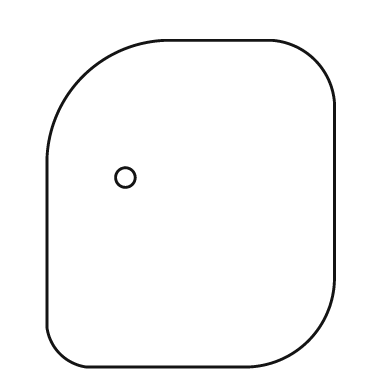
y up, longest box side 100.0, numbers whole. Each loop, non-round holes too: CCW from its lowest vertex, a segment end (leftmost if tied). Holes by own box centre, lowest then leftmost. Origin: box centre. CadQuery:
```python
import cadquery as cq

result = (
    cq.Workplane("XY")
    .moveTo(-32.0, -50.0)
    .lineTo(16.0, -50.0)
    .threePointArc((36.0, -42.0), (44.0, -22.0))
    .lineTo(44.0, 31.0)
    .threePointArc((38.0, 44.0), (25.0, 50.0))
    .lineTo(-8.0, 50.0)
    .threePointArc((-33.0, 39.0), (-44.0, 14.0))
    .lineTo(-44.0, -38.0)
    .threePointArc((-40.0, -46.0), (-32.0, -50.0))
    .close()
    .moveTo(-20.0, 8.0)
    .circle(3.0)
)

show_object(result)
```